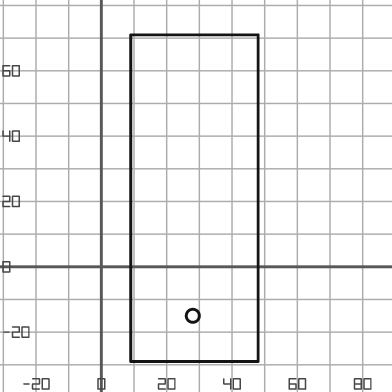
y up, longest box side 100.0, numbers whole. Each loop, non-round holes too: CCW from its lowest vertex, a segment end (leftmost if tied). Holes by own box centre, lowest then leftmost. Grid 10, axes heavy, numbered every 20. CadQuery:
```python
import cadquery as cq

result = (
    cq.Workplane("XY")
    .moveTo(9.0, -29.0)
    .lineTo(48.0, -29.0)
    .lineTo(48.0, 71.0)
    .lineTo(9.0, 71.0)
    .close()
    .moveTo(28.0, -15.0)
    .circle(2.0)
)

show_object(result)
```